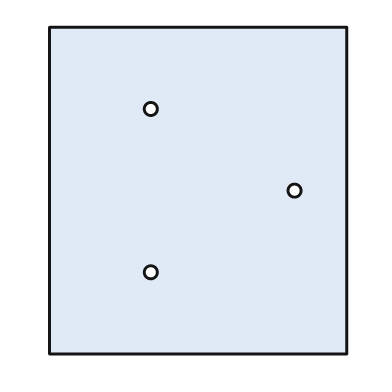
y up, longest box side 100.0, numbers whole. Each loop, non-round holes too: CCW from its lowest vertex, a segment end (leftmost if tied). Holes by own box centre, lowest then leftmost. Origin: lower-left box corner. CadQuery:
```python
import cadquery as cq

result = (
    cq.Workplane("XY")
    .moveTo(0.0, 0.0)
    .lineTo(91.0, 0.0)
    .lineTo(91.0, 100.0)
    .lineTo(0.0, 100.0)
    .close()
    .moveTo(31.0, 25.0)
    .circle(2.0)
    .moveTo(75.0, 50.0)
    .circle(2.0)
    .moveTo(31.0, 75.0)
    .circle(2.0)
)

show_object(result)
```